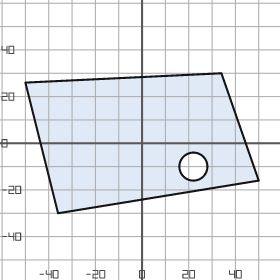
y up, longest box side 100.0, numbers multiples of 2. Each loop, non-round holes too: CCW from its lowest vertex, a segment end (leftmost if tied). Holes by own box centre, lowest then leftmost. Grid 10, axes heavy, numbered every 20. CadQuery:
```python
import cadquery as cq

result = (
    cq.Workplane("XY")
    .moveTo(-36.0, -30.0)
    .lineTo(50.0, -16.0)
    .lineTo(34.0, 30.0)
    .lineTo(-50.0, 26.0)
    .close()
    .moveTo(22.0, -10.0)
    .circle(6.0)
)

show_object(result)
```